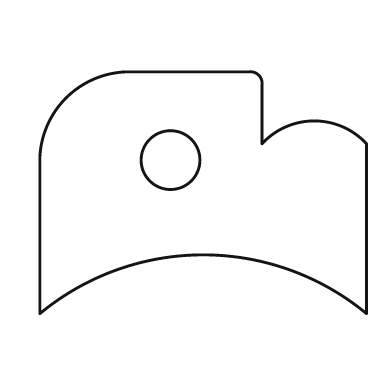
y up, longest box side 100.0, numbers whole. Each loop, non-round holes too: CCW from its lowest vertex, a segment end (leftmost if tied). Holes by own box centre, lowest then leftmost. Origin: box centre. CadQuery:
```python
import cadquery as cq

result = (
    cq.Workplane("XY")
    .moveTo(-50.0, -37.0)
    .threePointArc((0.0, -19.0), (50.0, -37.0))
    .lineTo(50.0, 15.0)
    .threePointArc((34.0, 22.0), (18.0, 15.0))
    .lineTo(18.0, 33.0)
    .threePointArc((17.0, 36.0), (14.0, 37.0))
    .lineTo(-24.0, 37.0)
    .threePointArc((-42.0, 29.0), (-50.0, 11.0))
    .close()
    .moveTo(-10.0, 10.0)
    .circle(9.0)
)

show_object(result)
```